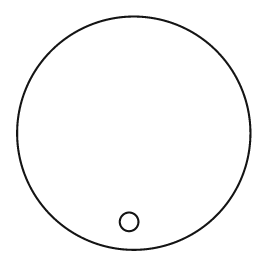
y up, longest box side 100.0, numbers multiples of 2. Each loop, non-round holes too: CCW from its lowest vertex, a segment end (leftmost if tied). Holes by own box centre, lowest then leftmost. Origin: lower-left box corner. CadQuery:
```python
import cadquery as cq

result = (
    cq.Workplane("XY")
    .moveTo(50.0, 50.0)
    .circle(50.0)
    .moveTo(48.0, 12.0)
    .circle(4.0)
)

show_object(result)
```